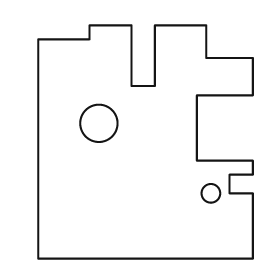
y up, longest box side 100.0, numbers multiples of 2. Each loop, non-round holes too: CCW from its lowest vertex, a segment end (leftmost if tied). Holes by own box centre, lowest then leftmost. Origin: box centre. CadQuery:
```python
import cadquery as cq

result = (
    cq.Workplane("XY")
    .moveTo(-46.0, -50.0)
    .lineTo(46.0, -50.0)
    .lineTo(46.0, -22.0)
    .lineTo(36.0, -22.0)
    .lineTo(36.0, -14.0)
    .lineTo(46.0, -14.0)
    .lineTo(46.0, -8.0)
    .lineTo(22.0, -8.0)
    .lineTo(22.0, 20.0)
    .lineTo(46.0, 20.0)
    .lineTo(46.0, 36.0)
    .lineTo(26.0, 36.0)
    .lineTo(26.0, 50.0)
    .lineTo(4.0, 50.0)
    .lineTo(4.0, 24.0)
    .lineTo(-6.0, 24.0)
    .lineTo(-6.0, 50.0)
    .lineTo(-24.0, 50.0)
    .lineTo(-24.0, 44.0)
    .lineTo(-46.0, 44.0)
    .close()
    .moveTo(28.0, -22.0)
    .circle(4.0)
    .moveTo(-20.0, 8.0)
    .circle(8.0)
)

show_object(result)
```